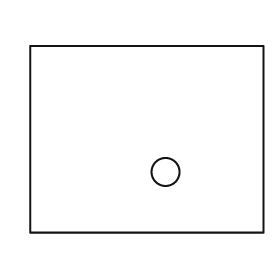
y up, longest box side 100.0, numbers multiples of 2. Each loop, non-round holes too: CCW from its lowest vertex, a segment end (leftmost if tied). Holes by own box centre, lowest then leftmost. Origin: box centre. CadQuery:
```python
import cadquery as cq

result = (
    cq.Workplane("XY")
    .moveTo(-50.0, -40.0)
    .lineTo(50.0, -40.0)
    .lineTo(50.0, 40.0)
    .lineTo(-50.0, 40.0)
    .close()
    .moveTo(8.0, -14.0)
    .circle(6.0)
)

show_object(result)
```